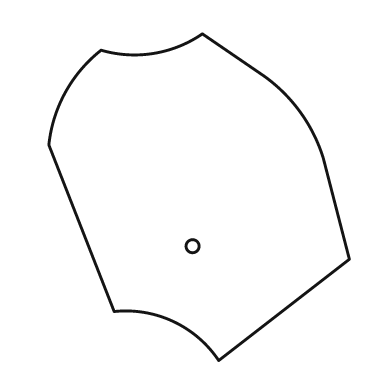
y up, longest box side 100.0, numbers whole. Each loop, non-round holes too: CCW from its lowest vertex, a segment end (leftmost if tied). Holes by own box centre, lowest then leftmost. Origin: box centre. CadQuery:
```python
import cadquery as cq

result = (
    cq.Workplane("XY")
    .moveTo(6.0, -50.0)
    .lineTo(46.0, -19.0)
    .lineTo(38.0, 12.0)
    .threePointArc((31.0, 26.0), (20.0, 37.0))
    .lineTo(1.0, 50.0)
    .threePointArc((-14.0, 44.0), (-30.0, 45.0))
    .threePointArc((-41.0, 32.0), (-46.0, 16.0))
    .lineTo(-26.0, -35.0)
    .threePointArc((-8.0, -38.0), (6.0, -50.0))
    .close()
    .moveTo(-2.0, -15.0)
    .circle(2.0)
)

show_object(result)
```